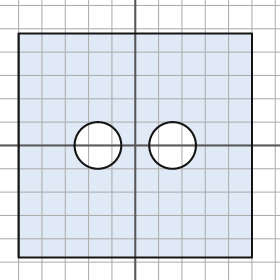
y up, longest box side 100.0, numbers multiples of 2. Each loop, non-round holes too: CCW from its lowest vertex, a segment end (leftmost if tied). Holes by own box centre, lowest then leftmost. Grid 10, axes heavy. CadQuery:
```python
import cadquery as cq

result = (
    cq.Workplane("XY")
    .moveTo(-50.0, -48.0)
    .lineTo(50.0, -48.0)
    .lineTo(50.0, 48.0)
    .lineTo(-50.0, 48.0)
    .close()
    .moveTo(-16.0, 0.0)
    .circle(10.0)
    .moveTo(16.0, 0.0)
    .circle(10.0)
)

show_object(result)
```